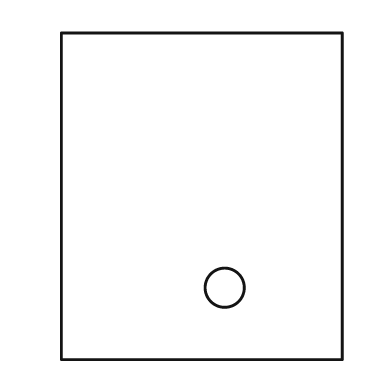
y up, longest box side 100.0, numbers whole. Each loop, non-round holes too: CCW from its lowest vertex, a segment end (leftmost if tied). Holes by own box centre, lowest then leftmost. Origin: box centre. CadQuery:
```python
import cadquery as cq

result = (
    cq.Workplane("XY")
    .moveTo(-43.0, -50.0)
    .lineTo(43.0, -50.0)
    .lineTo(43.0, 50.0)
    .lineTo(-43.0, 50.0)
    .close()
    .moveTo(7.0, -28.0)
    .circle(6.0)
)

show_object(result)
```